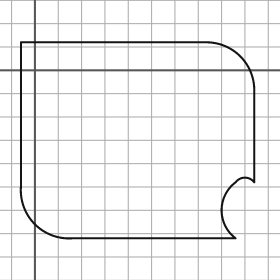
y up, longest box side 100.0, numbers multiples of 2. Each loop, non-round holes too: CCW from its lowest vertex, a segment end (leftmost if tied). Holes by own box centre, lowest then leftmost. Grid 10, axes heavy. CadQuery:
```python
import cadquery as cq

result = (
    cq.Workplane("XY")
    .moveTo(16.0, -72.0)
    .lineTo(86.0, -72.0)
    .threePointArc((80.0, -60.0), (86.0, -48.0))
    .threePointArc((90.0, -46.0), (94.0, -48.0))
    .lineTo(94.0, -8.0)
    .threePointArc((88.0, 6.0), (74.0, 12.0))
    .lineTo(-6.0, 12.0)
    .lineTo(-6.0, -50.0)
    .threePointArc((0.0, -66.0), (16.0, -72.0))
    .close()
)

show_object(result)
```